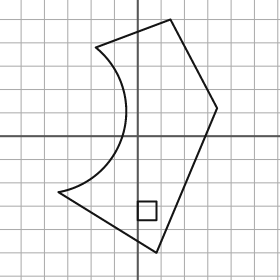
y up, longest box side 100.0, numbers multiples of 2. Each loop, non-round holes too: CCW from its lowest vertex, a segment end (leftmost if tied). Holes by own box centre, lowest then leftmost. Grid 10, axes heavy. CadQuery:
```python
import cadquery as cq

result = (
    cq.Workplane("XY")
    .moveTo(8.0, -50.0)
    .lineTo(34.0, 12.0)
    .lineTo(14.0, 50.0)
    .lineTo(-18.0, 38.0)
    .threePointArc((-6.0, 2.0), (-34.0, -24.0))
    .close()
    .moveTo(0.0, -36.0)
    .lineTo(8.0, -36.0)
    .lineTo(8.0, -28.0)
    .lineTo(0.0, -28.0)
    .close()
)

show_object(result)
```